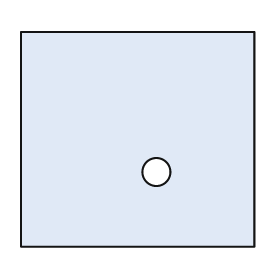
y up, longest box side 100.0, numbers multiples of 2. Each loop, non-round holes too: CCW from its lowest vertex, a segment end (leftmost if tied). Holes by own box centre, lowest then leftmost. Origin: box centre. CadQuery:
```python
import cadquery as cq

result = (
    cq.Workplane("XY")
    .moveTo(-50.0, -46.0)
    .lineTo(50.0, -46.0)
    .lineTo(50.0, 46.0)
    .lineTo(-50.0, 46.0)
    .close()
    .moveTo(8.0, -14.0)
    .circle(6.0)
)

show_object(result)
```